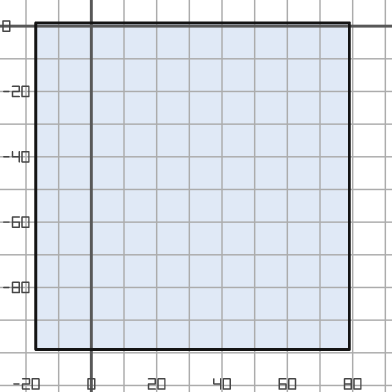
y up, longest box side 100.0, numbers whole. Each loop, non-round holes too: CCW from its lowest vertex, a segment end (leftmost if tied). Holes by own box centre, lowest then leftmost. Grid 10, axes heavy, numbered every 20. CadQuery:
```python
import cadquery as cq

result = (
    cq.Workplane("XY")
    .moveTo(-17.0, -99.0)
    .lineTo(79.0, -99.0)
    .lineTo(79.0, 1.0)
    .lineTo(-17.0, 1.0)
    .close()
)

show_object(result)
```